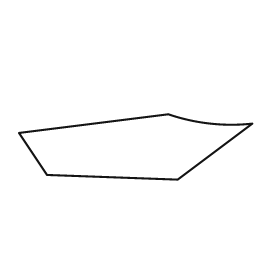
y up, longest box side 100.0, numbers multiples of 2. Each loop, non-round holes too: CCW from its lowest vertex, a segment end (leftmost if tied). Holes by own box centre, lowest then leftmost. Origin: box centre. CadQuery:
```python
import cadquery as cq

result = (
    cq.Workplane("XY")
    .moveTo(18.0, -14.0)
    .lineTo(50.0, 10.0)
    .threePointArc((32.0, 10.0), (14.0, 14.0))
    .lineTo(-50.0, 6.0)
    .lineTo(-38.0, -12.0)
    .close()
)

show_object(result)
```